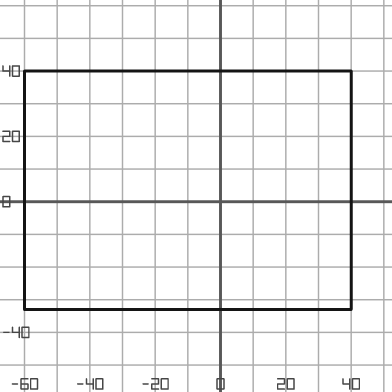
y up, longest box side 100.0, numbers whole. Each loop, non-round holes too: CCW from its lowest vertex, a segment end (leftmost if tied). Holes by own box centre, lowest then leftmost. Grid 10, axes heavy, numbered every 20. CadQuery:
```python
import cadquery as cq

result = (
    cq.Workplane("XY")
    .moveTo(-60.0, -33.0)
    .lineTo(40.0, -33.0)
    .lineTo(40.0, 40.0)
    .lineTo(-60.0, 40.0)
    .close()
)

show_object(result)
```